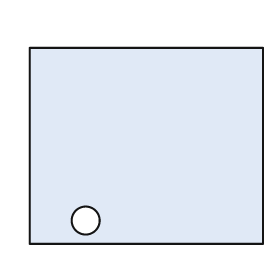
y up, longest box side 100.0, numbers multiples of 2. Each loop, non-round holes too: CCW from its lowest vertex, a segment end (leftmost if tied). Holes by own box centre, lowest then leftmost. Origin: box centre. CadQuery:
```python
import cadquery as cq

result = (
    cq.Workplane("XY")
    .moveTo(-50.0, -42.0)
    .lineTo(50.0, -42.0)
    .lineTo(50.0, 42.0)
    .lineTo(-50.0, 42.0)
    .close()
    .moveTo(-26.0, -32.0)
    .circle(6.0)
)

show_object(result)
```